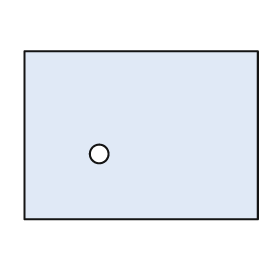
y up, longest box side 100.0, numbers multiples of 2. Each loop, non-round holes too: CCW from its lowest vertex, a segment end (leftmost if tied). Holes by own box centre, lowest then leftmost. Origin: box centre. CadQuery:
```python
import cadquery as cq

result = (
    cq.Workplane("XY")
    .moveTo(-50.0, -36.0)
    .lineTo(50.0, -36.0)
    .lineTo(50.0, 36.0)
    .lineTo(-50.0, 36.0)
    .close()
    .moveTo(-18.0, -8.0)
    .circle(4.0)
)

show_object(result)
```